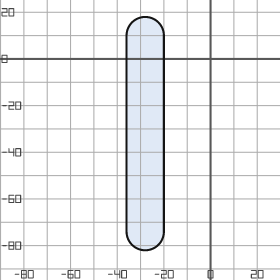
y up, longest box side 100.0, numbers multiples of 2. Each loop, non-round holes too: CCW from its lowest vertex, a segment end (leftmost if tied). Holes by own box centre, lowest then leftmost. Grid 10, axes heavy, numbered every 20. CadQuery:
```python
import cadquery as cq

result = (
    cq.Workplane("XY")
    .moveTo(-36.0, -74.0)
    .threePointArc((-28.0, -82.0), (-20.0, -74.0))
    .lineTo(-20.0, 10.0)
    .threePointArc((-28.0, 18.0), (-36.0, 10.0))
    .close()
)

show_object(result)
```